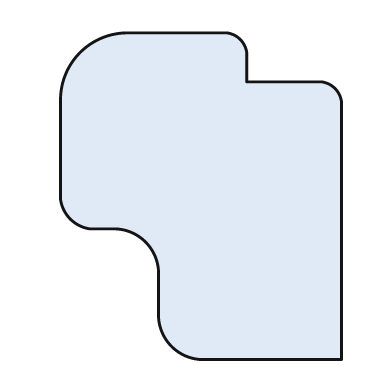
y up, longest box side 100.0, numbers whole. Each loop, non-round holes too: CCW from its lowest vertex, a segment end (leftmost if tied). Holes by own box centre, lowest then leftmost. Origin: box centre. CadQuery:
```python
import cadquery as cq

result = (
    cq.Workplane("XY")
    .moveTo(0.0, -50.0)
    .lineTo(43.0, -50.0)
    .lineTo(43.0, 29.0)
    .threePointArc((41.0, 33.0), (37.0, 35.0))
    .lineTo(14.0, 35.0)
    .lineTo(14.0, 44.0)
    .threePointArc((12.0, 48.0), (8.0, 50.0))
    .lineTo(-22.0, 50.0)
    .threePointArc((-37.0, 44.0), (-43.0, 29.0))
    .lineTo(-43.0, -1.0)
    .threePointArc((-40.0, -7.0), (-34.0, -10.0))
    .lineTo(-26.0, -10.0)
    .threePointArc((-17.0, -14.0), (-13.0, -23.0))
    .lineTo(-13.0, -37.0)
    .threePointArc((-9.0, -46.0), (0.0, -50.0))
    .close()
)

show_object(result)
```